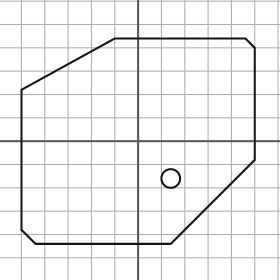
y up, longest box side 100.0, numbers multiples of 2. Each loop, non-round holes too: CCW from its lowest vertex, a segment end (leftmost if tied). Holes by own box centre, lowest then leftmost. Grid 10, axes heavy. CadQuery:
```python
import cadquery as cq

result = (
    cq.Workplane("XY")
    .moveTo(-44.0, -44.0)
    .lineTo(14.0, -44.0)
    .lineTo(50.0, -8.0)
    .lineTo(50.0, 40.0)
    .lineTo(46.0, 44.0)
    .lineTo(-10.0, 44.0)
    .lineTo(-50.0, 22.0)
    .lineTo(-50.0, -38.0)
    .close()
    .moveTo(14.0, -16.0)
    .circle(4.0)
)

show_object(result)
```